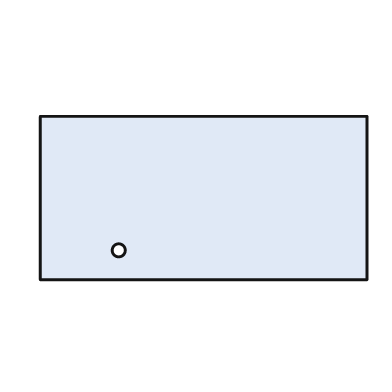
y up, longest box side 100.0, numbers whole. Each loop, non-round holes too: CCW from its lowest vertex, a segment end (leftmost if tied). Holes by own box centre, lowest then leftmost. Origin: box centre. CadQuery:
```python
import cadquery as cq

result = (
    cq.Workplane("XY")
    .moveTo(-50.0, -25.0)
    .lineTo(50.0, -25.0)
    .lineTo(50.0, 25.0)
    .lineTo(-50.0, 25.0)
    .close()
    .moveTo(-26.0, -16.0)
    .circle(2.0)
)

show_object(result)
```